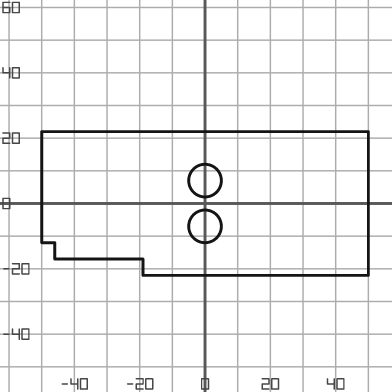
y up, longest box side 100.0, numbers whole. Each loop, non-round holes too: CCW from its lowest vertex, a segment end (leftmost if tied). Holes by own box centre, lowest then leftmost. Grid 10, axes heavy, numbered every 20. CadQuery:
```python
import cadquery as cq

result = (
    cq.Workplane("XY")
    .moveTo(-19.0, -22.0)
    .lineTo(50.0, -22.0)
    .lineTo(50.0, 22.0)
    .lineTo(-50.0, 22.0)
    .lineTo(-50.0, -12.0)
    .lineTo(-46.0, -12.0)
    .lineTo(-46.0, -17.0)
    .lineTo(-19.0, -17.0)
    .close()
    .moveTo(0.0, -7.0)
    .circle(5.0)
    .moveTo(0.0, 7.0)
    .circle(5.0)
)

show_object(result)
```